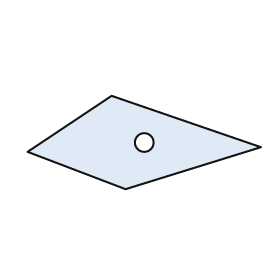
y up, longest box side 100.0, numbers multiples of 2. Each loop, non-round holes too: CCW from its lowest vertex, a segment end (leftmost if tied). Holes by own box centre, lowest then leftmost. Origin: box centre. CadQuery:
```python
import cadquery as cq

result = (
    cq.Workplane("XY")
    .moveTo(-8.0, -20.0)
    .lineTo(50.0, -2.0)
    .lineTo(-14.0, 20.0)
    .lineTo(-50.0, -4.0)
    .close()
    .moveTo(0.0, 0.0)
    .circle(4.0)
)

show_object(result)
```